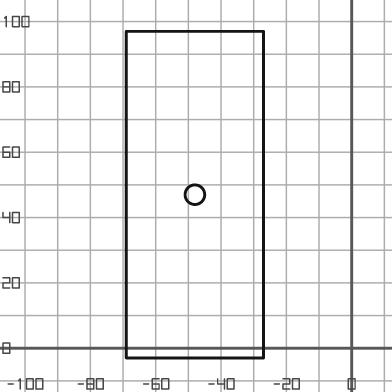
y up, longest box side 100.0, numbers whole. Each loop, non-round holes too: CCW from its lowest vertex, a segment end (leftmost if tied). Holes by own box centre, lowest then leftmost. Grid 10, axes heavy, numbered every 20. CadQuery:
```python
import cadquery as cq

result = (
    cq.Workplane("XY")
    .moveTo(-69.0, -3.0)
    .lineTo(-27.0, -3.0)
    .lineTo(-27.0, 97.0)
    .lineTo(-69.0, 97.0)
    .close()
    .moveTo(-48.0, 47.0)
    .circle(3.0)
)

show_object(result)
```